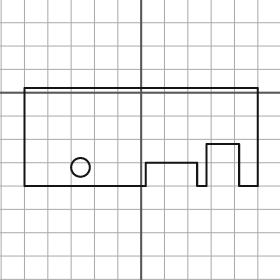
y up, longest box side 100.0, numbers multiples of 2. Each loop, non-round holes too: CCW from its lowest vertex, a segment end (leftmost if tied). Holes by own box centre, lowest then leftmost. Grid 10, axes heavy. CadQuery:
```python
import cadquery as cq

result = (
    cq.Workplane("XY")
    .moveTo(-50.0, -40.0)
    .lineTo(2.0, -40.0)
    .lineTo(2.0, -30.0)
    .lineTo(24.0, -30.0)
    .lineTo(24.0, -40.0)
    .lineTo(28.0, -40.0)
    .lineTo(28.0, -22.0)
    .lineTo(42.0, -22.0)
    .lineTo(42.0, -40.0)
    .lineTo(50.0, -40.0)
    .lineTo(50.0, 2.0)
    .lineTo(-50.0, 2.0)
    .close()
    .moveTo(-26.0, -32.0)
    .circle(4.0)
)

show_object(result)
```